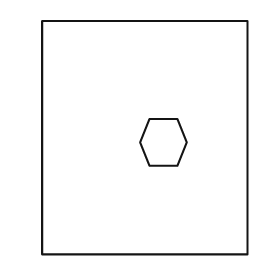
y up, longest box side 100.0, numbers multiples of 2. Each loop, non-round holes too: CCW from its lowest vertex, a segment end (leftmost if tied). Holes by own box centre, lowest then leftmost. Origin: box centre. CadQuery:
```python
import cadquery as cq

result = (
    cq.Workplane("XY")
    .moveTo(-44.0, -50.0)
    .lineTo(44.0, -50.0)
    .lineTo(44.0, 50.0)
    .lineTo(-44.0, 50.0)
    .close()
    .moveTo(2.0, -12.0)
    .lineTo(14.0, -12.0)
    .lineTo(18.0, -2.0)
    .lineTo(14.0, 8.0)
    .lineTo(2.0, 8.0)
    .lineTo(-2.0, -2.0)
    .close()
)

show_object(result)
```